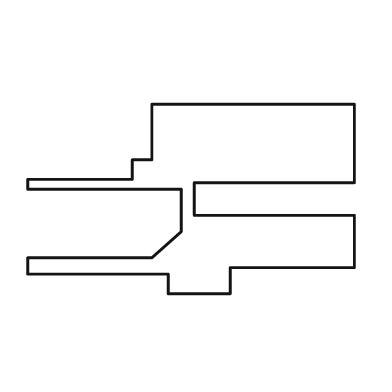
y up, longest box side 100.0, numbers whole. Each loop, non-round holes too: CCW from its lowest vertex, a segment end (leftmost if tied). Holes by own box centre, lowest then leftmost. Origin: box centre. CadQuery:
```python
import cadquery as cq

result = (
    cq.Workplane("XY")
    .moveTo(-7.0, -29.0)
    .lineTo(12.0, -29.0)
    .lineTo(12.0, -21.0)
    .lineTo(50.0, -21.0)
    .lineTo(50.0, -5.0)
    .lineTo(1.0, -5.0)
    .lineTo(1.0, 5.0)
    .lineTo(50.0, 5.0)
    .lineTo(50.0, 29.0)
    .lineTo(-12.0, 29.0)
    .lineTo(-12.0, 12.0)
    .lineTo(-18.0, 12.0)
    .lineTo(-18.0, 6.0)
    .lineTo(-50.0, 6.0)
    .lineTo(-50.0, 3.0)
    .lineTo(-3.0, 3.0)
    .lineTo(-3.0, -10.0)
    .lineTo(-12.0, -18.0)
    .lineTo(-50.0, -18.0)
    .lineTo(-50.0, -23.0)
    .lineTo(-7.0, -23.0)
    .close()
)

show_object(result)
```